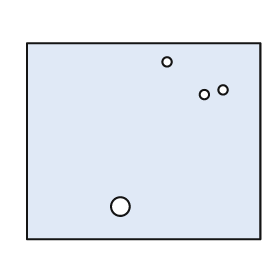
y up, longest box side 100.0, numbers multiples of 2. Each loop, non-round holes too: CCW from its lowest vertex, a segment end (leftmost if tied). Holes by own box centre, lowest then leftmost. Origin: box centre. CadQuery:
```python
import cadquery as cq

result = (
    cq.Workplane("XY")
    .moveTo(-50.0, -42.0)
    .lineTo(50.0, -42.0)
    .lineTo(50.0, 42.0)
    .lineTo(-50.0, 42.0)
    .close()
    .moveTo(-10.0, -28.0)
    .circle(4.0)
    .moveTo(26.0, 20.0)
    .circle(2.0)
    .moveTo(34.0, 22.0)
    .circle(2.0)
    .moveTo(10.0, 34.0)
    .circle(2.0)
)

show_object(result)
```